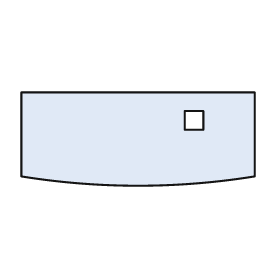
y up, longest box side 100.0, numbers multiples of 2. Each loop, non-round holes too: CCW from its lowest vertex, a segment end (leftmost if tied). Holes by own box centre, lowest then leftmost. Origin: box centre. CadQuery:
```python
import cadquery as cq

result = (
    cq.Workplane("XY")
    .moveTo(-50.0, -16.0)
    .threePointArc((0.0, -20.0), (50.0, -16.0))
    .lineTo(50.0, 20.0)
    .lineTo(-50.0, 20.0)
    .close()
    .moveTo(20.0, 4.0)
    .lineTo(28.0, 4.0)
    .lineTo(28.0, 12.0)
    .lineTo(20.0, 12.0)
    .close()
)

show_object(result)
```